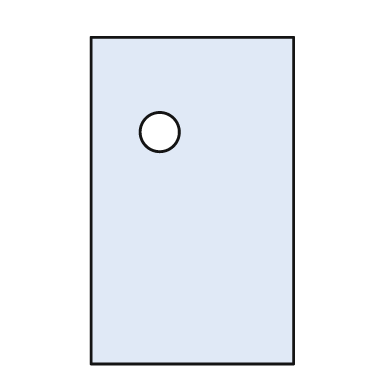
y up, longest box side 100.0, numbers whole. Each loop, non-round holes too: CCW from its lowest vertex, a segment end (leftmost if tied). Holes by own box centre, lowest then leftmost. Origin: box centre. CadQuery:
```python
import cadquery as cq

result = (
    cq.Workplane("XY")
    .moveTo(-31.0, -50.0)
    .lineTo(31.0, -50.0)
    .lineTo(31.0, 50.0)
    .lineTo(-31.0, 50.0)
    .close()
    .moveTo(-10.0, 21.0)
    .circle(6.0)
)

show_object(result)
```